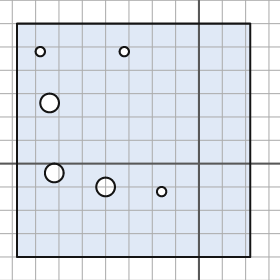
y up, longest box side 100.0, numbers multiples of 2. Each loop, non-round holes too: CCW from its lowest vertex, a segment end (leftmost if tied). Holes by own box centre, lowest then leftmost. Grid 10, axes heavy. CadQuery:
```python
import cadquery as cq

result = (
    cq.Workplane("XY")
    .moveTo(-78.0, -40.0)
    .lineTo(22.0, -40.0)
    .lineTo(22.0, 60.0)
    .lineTo(-78.0, 60.0)
    .close()
    .moveTo(-16.0, -12.0)
    .circle(2.0)
    .moveTo(-40.0, -10.0)
    .circle(4.0)
    .moveTo(-62.0, -4.0)
    .circle(4.0)
    .moveTo(-64.0, 26.0)
    .circle(4.0)
    .moveTo(-68.0, 48.0)
    .circle(2.0)
    .moveTo(-32.0, 48.0)
    .circle(2.0)
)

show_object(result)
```